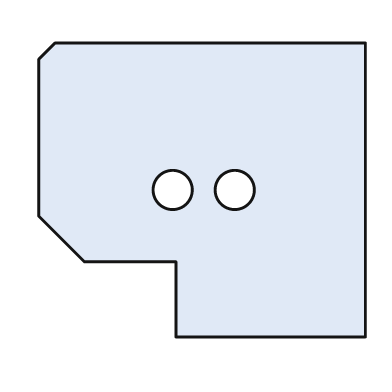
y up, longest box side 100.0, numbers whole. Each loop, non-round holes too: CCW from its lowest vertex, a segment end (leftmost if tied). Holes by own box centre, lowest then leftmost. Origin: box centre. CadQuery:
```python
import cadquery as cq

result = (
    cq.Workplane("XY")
    .moveTo(-8.0, -45.0)
    .lineTo(50.0, -45.0)
    .lineTo(50.0, 45.0)
    .lineTo(-45.0, 45.0)
    .lineTo(-50.0, 40.0)
    .lineTo(-50.0, -8.0)
    .lineTo(-36.0, -22.0)
    .lineTo(-8.0, -22.0)
    .close()
    .moveTo(-9.0, 0.0)
    .circle(6.0)
    .moveTo(10.0, 0.0)
    .circle(6.0)
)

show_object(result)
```